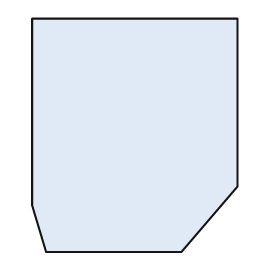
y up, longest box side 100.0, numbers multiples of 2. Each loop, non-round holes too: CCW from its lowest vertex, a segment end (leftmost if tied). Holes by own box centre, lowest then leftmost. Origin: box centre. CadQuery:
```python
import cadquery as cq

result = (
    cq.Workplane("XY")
    .moveTo(-38.0, -50.0)
    .lineTo(20.0, -50.0)
    .lineTo(44.0, -22.0)
    .lineTo(44.0, 50.0)
    .lineTo(-44.0, 50.0)
    .lineTo(-44.0, -30.0)
    .close()
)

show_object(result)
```